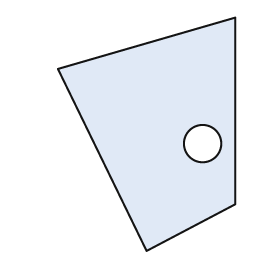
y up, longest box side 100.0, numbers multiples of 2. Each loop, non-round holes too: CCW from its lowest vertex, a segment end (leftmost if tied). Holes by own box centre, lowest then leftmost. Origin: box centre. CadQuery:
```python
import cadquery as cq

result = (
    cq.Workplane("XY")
    .moveTo(0.0, -50.0)
    .lineTo(38.0, -30.0)
    .lineTo(38.0, 50.0)
    .lineTo(-38.0, 28.0)
    .close()
    .moveTo(24.0, -4.0)
    .circle(8.0)
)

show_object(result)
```